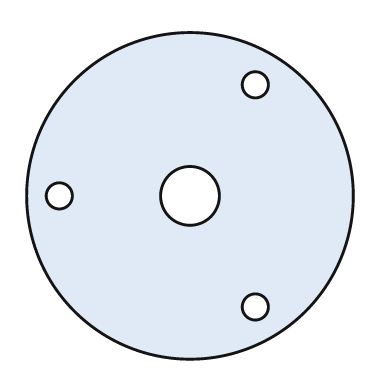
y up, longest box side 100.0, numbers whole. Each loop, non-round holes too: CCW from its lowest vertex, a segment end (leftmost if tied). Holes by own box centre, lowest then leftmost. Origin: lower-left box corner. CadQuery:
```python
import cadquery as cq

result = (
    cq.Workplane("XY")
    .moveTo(50.0, 50.0)
    .circle(50.0)
    .moveTo(70.0, 16.0)
    .circle(4.0)
    .moveTo(10.0, 50.0)
    .circle(4.0)
    .moveTo(50.0, 50.0)
    .circle(9.0)
    .moveTo(70.0, 84.0)
    .circle(4.0)
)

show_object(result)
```